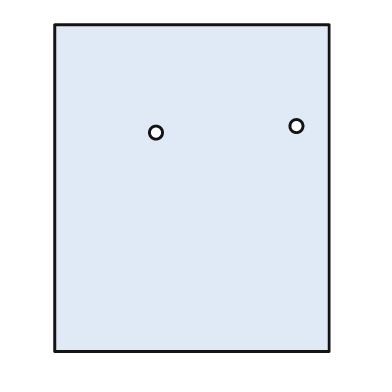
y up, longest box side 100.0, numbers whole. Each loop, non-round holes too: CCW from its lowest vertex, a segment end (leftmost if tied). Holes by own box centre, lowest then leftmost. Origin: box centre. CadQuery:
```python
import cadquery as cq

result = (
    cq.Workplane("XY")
    .moveTo(-42.0, -50.0)
    .lineTo(42.0, -50.0)
    .lineTo(42.0, 50.0)
    .lineTo(-42.0, 50.0)
    .close()
    .moveTo(-11.0, 17.0)
    .circle(2.0)
    .moveTo(32.0, 19.0)
    .circle(2.0)
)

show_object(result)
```